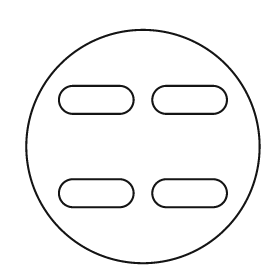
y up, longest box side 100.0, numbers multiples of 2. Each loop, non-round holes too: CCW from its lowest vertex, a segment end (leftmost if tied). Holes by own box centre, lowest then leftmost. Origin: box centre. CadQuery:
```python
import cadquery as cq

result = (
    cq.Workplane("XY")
    .moveTo(0.0, 0.0)
    .circle(50.0)
    .moveTo(-30.0, -26.0)
    .lineTo(-10.0, -26.0)
    .threePointArc((-4.0, -20.0), (-10.0, -14.0))
    .lineTo(-30.0, -14.0)
    .threePointArc((-36.0, -20.0), (-30.0, -26.0))
    .close()
    .moveTo(10.0, -26.0)
    .lineTo(30.0, -26.0)
    .threePointArc((36.0, -20.0), (30.0, -14.0))
    .lineTo(10.0, -14.0)
    .threePointArc((4.0, -20.0), (10.0, -26.0))
    .close()
    .moveTo(-30.0, 14.0)
    .lineTo(-10.0, 14.0)
    .threePointArc((-4.0, 20.0), (-10.0, 26.0))
    .lineTo(-30.0, 26.0)
    .threePointArc((-36.0, 20.0), (-30.0, 14.0))
    .close()
    .moveTo(10.0, 14.0)
    .lineTo(30.0, 14.0)
    .threePointArc((36.0, 20.0), (30.0, 26.0))
    .lineTo(10.0, 26.0)
    .threePointArc((4.0, 20.0), (10.0, 14.0))
    .close()
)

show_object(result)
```